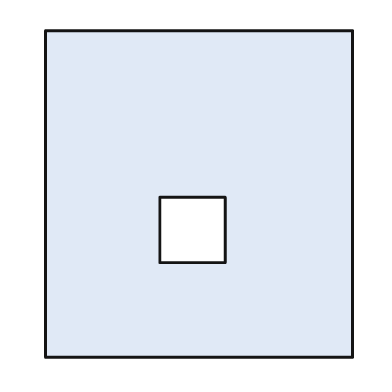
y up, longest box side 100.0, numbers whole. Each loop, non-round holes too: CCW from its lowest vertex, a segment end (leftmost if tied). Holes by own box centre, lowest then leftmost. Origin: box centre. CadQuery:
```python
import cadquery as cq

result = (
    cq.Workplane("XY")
    .moveTo(-47.0, -50.0)
    .lineTo(47.0, -50.0)
    .lineTo(47.0, 50.0)
    .lineTo(-47.0, 50.0)
    .close()
    .moveTo(-12.0, -21.0)
    .lineTo(8.0, -21.0)
    .lineTo(8.0, -1.0)
    .lineTo(-12.0, -1.0)
    .close()
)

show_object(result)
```